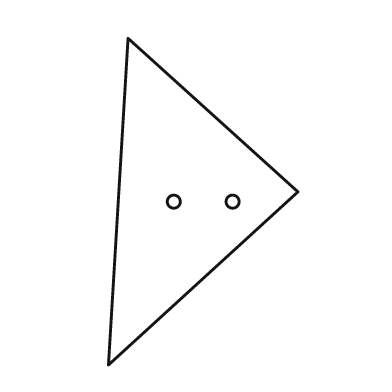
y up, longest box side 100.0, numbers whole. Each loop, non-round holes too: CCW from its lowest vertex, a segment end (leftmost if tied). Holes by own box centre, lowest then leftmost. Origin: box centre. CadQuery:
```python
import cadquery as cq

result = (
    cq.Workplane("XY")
    .moveTo(-29.0, -50.0)
    .lineTo(29.0, 3.0)
    .lineTo(-23.0, 50.0)
    .close()
    .moveTo(-9.0, 0.0)
    .circle(2.0)
    .moveTo(9.0, 0.0)
    .circle(2.0)
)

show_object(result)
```